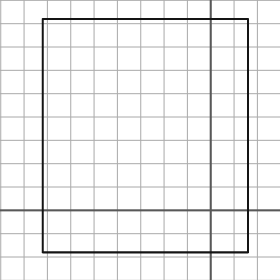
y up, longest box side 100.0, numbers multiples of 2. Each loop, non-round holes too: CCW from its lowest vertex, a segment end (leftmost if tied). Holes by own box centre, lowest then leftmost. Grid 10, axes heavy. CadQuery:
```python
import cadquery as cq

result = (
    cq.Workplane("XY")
    .moveTo(-72.0, -18.0)
    .lineTo(16.0, -18.0)
    .lineTo(16.0, 82.0)
    .lineTo(-72.0, 82.0)
    .close()
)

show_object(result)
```